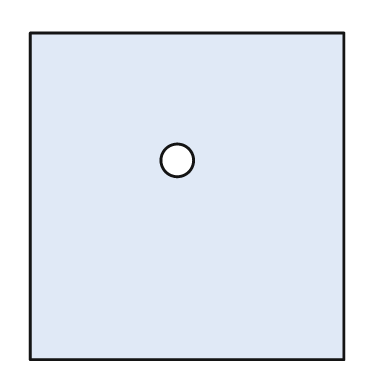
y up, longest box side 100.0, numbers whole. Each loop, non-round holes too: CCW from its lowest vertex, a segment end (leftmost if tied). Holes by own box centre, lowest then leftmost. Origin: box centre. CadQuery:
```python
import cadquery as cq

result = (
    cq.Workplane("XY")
    .moveTo(-48.0, -50.0)
    .lineTo(48.0, -50.0)
    .lineTo(48.0, 50.0)
    .lineTo(-48.0, 50.0)
    .close()
    .moveTo(-3.0, 11.0)
    .circle(5.0)
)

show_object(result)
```